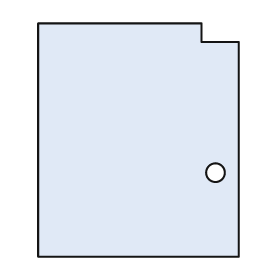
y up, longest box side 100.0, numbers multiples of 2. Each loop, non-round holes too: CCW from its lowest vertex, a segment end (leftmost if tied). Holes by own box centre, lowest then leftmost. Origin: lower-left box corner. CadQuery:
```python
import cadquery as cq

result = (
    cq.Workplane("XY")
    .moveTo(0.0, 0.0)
    .lineTo(86.0, 0.0)
    .lineTo(86.0, 92.0)
    .lineTo(70.0, 92.0)
    .lineTo(70.0, 100.0)
    .lineTo(0.0, 100.0)
    .close()
    .moveTo(76.0, 36.0)
    .circle(4.0)
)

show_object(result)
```